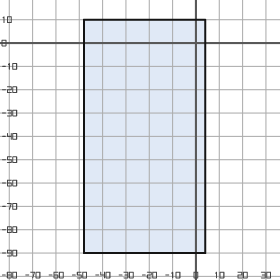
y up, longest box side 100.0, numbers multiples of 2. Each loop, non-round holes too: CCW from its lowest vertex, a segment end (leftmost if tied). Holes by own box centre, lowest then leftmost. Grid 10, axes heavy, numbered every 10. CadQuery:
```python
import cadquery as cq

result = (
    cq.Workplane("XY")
    .moveTo(-48.0, -90.0)
    .lineTo(4.0, -90.0)
    .lineTo(4.0, 10.0)
    .lineTo(-48.0, 10.0)
    .close()
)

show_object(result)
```